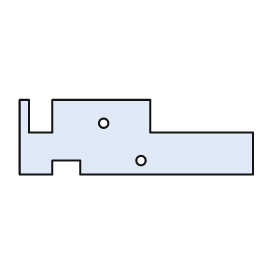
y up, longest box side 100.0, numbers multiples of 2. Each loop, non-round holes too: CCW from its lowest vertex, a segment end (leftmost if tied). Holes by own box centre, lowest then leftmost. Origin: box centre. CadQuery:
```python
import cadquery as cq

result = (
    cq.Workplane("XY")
    .moveTo(-50.0, -16.0)
    .lineTo(-36.0, -16.0)
    .lineTo(-36.0, -10.0)
    .lineTo(-24.0, -10.0)
    .lineTo(-24.0, -16.0)
    .lineTo(50.0, -16.0)
    .lineTo(50.0, 2.0)
    .lineTo(6.0, 2.0)
    .lineTo(6.0, 16.0)
    .lineTo(-36.0, 16.0)
    .lineTo(-36.0, 2.0)
    .lineTo(-46.0, 2.0)
    .lineTo(-46.0, 16.0)
    .lineTo(-50.0, 16.0)
    .close()
    .moveTo(2.0, -10.0)
    .circle(2.0)
    .moveTo(-14.0, 6.0)
    .circle(2.0)
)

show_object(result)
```